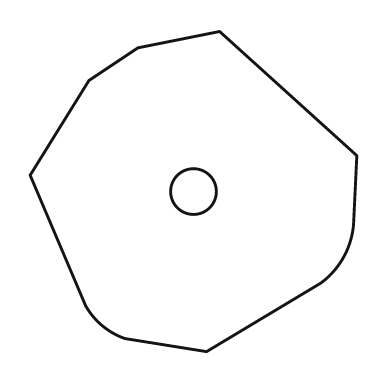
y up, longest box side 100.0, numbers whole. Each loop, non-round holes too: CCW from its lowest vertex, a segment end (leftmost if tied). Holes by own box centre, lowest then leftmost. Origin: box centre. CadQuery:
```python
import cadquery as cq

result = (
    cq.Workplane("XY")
    .moveTo(4.0, -49.0)
    .lineTo(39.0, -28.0)
    .threePointArc((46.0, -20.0), (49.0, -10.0))
    .lineTo(50.0, 11.0)
    .lineTo(8.0, 49.0)
    .lineTo(-17.0, 44.0)
    .lineTo(-32.0, 34.0)
    .lineTo(-50.0, 5.0)
    .lineTo(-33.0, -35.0)
    .threePointArc((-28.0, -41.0), (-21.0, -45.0))
    .close()
    .moveTo(0.0, 0.0)
    .circle(7.0)
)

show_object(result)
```